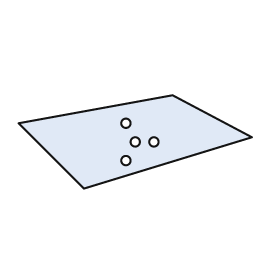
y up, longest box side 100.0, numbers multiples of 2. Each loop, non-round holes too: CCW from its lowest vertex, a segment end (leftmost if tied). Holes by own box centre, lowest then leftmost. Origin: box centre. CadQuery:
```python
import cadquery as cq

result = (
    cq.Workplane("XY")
    .moveTo(-22.0, -20.0)
    .lineTo(50.0, 2.0)
    .lineTo(16.0, 20.0)
    .lineTo(-50.0, 8.0)
    .close()
    .moveTo(-4.0, -8.0)
    .circle(2.0)
    .moveTo(0.0, 0.0)
    .circle(2.0)
    .moveTo(8.0, 0.0)
    .circle(2.0)
    .moveTo(-4.0, 8.0)
    .circle(2.0)
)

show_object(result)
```